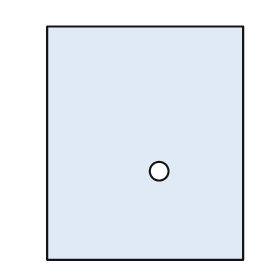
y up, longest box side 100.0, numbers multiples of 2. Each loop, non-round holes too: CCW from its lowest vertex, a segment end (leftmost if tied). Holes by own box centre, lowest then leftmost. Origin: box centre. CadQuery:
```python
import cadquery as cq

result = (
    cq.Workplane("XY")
    .moveTo(-42.0, -50.0)
    .lineTo(42.0, -50.0)
    .lineTo(42.0, 50.0)
    .lineTo(-42.0, 50.0)
    .close()
    .moveTo(6.0, -12.0)
    .circle(4.0)
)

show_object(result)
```